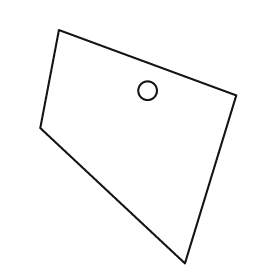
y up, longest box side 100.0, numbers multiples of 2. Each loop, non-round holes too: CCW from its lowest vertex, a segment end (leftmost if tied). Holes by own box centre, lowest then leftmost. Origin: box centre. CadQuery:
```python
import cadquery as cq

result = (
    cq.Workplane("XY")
    .moveTo(20.0, -50.0)
    .lineTo(42.0, 22.0)
    .lineTo(-34.0, 50.0)
    .lineTo(-42.0, 8.0)
    .close()
    .moveTo(4.0, 24.0)
    .circle(4.0)
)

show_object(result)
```